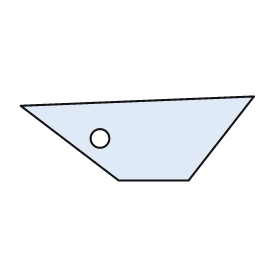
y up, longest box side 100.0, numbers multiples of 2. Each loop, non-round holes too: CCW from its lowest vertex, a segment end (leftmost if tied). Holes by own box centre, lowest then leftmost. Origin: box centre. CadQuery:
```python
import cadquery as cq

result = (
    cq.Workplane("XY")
    .moveTo(-8.0, -18.0)
    .lineTo(22.0, -18.0)
    .lineTo(50.0, 18.0)
    .lineTo(-50.0, 14.0)
    .close()
    .moveTo(-16.0, 0.0)
    .circle(4.0)
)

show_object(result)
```